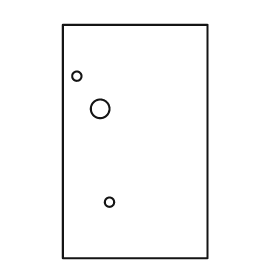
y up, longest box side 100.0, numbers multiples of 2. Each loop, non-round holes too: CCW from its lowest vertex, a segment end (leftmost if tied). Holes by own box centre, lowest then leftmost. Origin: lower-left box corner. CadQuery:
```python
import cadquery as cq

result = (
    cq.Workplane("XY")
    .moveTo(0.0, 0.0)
    .lineTo(62.0, 0.0)
    .lineTo(62.0, 100.0)
    .lineTo(0.0, 100.0)
    .close()
    .moveTo(20.0, 24.0)
    .circle(2.0)
    .moveTo(16.0, 64.0)
    .circle(4.0)
    .moveTo(6.0, 78.0)
    .circle(2.0)
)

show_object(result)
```